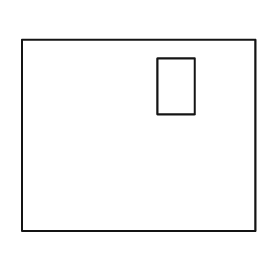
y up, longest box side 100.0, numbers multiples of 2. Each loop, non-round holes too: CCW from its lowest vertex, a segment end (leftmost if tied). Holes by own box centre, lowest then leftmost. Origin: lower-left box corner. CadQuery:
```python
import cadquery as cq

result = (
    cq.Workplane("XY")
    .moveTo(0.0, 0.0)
    .lineTo(100.0, 0.0)
    .lineTo(100.0, 82.0)
    .lineTo(0.0, 82.0)
    .close()
    .moveTo(58.0, 50.0)
    .lineTo(74.0, 50.0)
    .lineTo(74.0, 74.0)
    .lineTo(58.0, 74.0)
    .close()
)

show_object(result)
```